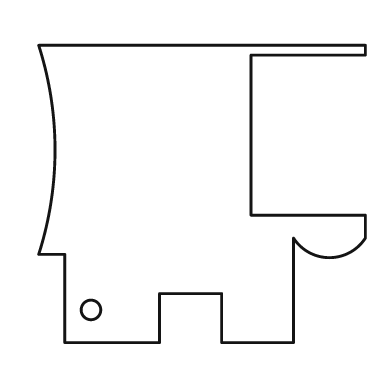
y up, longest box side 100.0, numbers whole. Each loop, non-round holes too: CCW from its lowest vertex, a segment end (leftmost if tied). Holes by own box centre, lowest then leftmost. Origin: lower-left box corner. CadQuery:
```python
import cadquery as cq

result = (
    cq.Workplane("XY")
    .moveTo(8.0, 0.0)
    .lineTo(37.0, 0.0)
    .lineTo(37.0, 15.0)
    .lineTo(56.0, 15.0)
    .lineTo(56.0, 0.0)
    .lineTo(78.0, 0.0)
    .lineTo(78.0, 32.0)
    .threePointArc((89.0, 26.0), (100.0, 32.0))
    .lineTo(100.0, 39.0)
    .lineTo(65.0, 39.0)
    .lineTo(65.0, 88.0)
    .lineTo(100.0, 88.0)
    .lineTo(100.0, 91.0)
    .lineTo(0.0, 91.0)
    .threePointArc((5.0, 59.0), (0.0, 27.0))
    .lineTo(8.0, 27.0)
    .close()
    .moveTo(16.0, 10.0)
    .circle(3.0)
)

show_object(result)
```